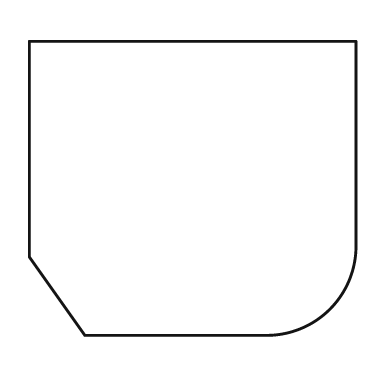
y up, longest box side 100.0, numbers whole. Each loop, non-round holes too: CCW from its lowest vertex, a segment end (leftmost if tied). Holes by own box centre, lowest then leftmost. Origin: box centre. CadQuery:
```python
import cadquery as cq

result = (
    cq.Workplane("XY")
    .moveTo(-33.0, -45.0)
    .lineTo(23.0, -45.0)
    .threePointArc((42.0, -37.0), (50.0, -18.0))
    .lineTo(50.0, 45.0)
    .lineTo(-50.0, 45.0)
    .lineTo(-50.0, -21.0)
    .close()
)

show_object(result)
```